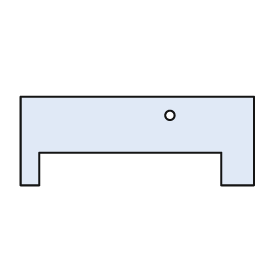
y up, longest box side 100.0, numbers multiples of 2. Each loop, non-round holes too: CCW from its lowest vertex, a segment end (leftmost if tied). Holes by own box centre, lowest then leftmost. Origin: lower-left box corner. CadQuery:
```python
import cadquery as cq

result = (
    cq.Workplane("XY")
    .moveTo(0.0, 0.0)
    .lineTo(8.0, 0.0)
    .lineTo(8.0, 14.0)
    .lineTo(86.0, 14.0)
    .lineTo(86.0, 0.0)
    .lineTo(100.0, 0.0)
    .lineTo(100.0, 38.0)
    .lineTo(0.0, 38.0)
    .close()
    .moveTo(64.0, 30.0)
    .circle(2.0)
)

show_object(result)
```